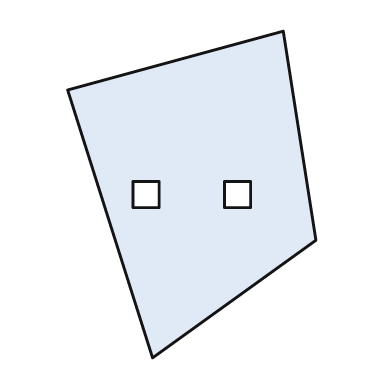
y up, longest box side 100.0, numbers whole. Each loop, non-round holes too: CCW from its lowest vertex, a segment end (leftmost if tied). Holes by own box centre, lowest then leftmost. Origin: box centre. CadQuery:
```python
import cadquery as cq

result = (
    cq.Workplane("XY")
    .moveTo(-12.0, -50.0)
    .lineTo(38.0, -14.0)
    .lineTo(28.0, 50.0)
    .lineTo(-38.0, 32.0)
    .close()
    .moveTo(-18.0, -4.0)
    .lineTo(-10.0, -4.0)
    .lineTo(-10.0, 4.0)
    .lineTo(-18.0, 4.0)
    .close()
    .moveTo(10.0, -4.0)
    .lineTo(18.0, -4.0)
    .lineTo(18.0, 4.0)
    .lineTo(10.0, 4.0)
    .close()
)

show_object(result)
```